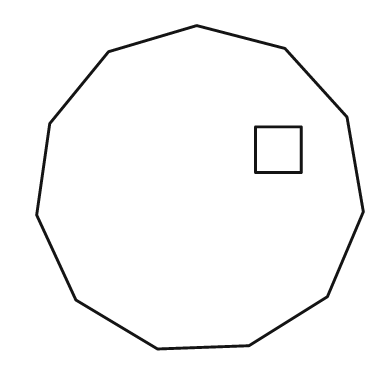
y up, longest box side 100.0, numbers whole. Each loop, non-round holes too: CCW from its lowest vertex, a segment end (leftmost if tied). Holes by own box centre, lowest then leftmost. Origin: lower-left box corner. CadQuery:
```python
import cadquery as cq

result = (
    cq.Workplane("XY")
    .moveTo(37.0, 0.0)
    .lineTo(65.0, 1.0)
    .lineTo(89.0, 16.0)
    .lineTo(100.0, 42.0)
    .lineTo(95.0, 71.0)
    .lineTo(76.0, 92.0)
    .lineTo(49.0, 99.0)
    .lineTo(22.0, 91.0)
    .lineTo(4.0, 69.0)
    .lineTo(0.0, 41.0)
    .lineTo(12.0, 15.0)
    .close()
    .moveTo(67.0, 54.0)
    .lineTo(81.0, 54.0)
    .lineTo(81.0, 68.0)
    .lineTo(67.0, 68.0)
    .close()
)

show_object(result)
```